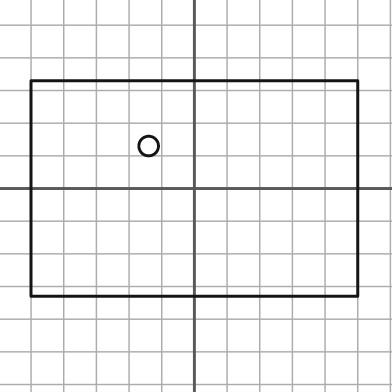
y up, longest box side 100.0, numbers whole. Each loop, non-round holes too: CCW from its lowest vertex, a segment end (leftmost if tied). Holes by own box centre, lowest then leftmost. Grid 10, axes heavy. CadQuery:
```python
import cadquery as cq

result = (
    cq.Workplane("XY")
    .moveTo(-50.0, -33.0)
    .lineTo(50.0, -33.0)
    .lineTo(50.0, 33.0)
    .lineTo(-50.0, 33.0)
    .close()
    .moveTo(-14.0, 13.0)
    .circle(3.0)
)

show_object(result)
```